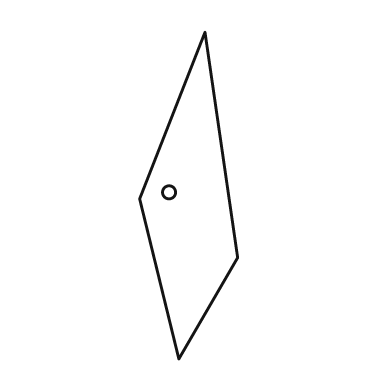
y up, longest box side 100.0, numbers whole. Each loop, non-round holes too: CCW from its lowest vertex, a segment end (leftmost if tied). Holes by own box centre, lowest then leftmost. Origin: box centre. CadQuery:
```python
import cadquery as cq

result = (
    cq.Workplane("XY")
    .moveTo(-3.0, -50.0)
    .lineTo(15.0, -19.0)
    .lineTo(5.0, 50.0)
    .lineTo(-15.0, -1.0)
    .close()
    .moveTo(-6.0, 1.0)
    .circle(2.0)
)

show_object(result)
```